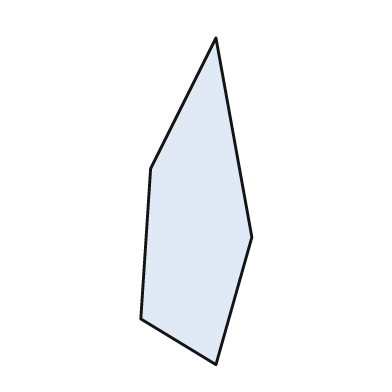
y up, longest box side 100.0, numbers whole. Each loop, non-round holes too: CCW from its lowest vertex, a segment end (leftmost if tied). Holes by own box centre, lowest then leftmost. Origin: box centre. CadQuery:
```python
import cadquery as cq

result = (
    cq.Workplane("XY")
    .moveTo(6.0, -50.0)
    .lineTo(17.0, -11.0)
    .lineTo(6.0, 50.0)
    .lineTo(-14.0, 10.0)
    .lineTo(-17.0, -36.0)
    .close()
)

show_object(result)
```